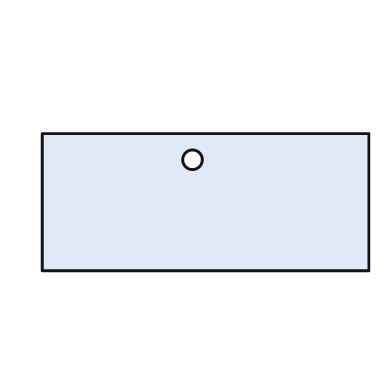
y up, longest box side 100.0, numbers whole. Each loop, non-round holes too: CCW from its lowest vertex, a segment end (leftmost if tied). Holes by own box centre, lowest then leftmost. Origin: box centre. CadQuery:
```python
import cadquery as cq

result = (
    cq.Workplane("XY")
    .moveTo(-50.0, -21.0)
    .lineTo(50.0, -21.0)
    .lineTo(50.0, 21.0)
    .lineTo(-50.0, 21.0)
    .close()
    .moveTo(-4.0, 13.0)
    .circle(3.0)
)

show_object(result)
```